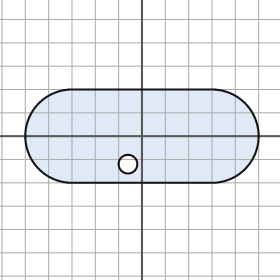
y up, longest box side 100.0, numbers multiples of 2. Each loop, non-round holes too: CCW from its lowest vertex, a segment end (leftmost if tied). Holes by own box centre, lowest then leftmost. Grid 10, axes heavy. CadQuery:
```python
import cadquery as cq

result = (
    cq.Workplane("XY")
    .moveTo(-30.0, -20.0)
    .lineTo(30.0, -20.0)
    .threePointArc((50.0, 0.0), (30.0, 20.0))
    .lineTo(-30.0, 20.0)
    .threePointArc((-50.0, 0.0), (-30.0, -20.0))
    .close()
    .moveTo(-6.0, -12.0)
    .circle(4.0)
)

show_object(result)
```